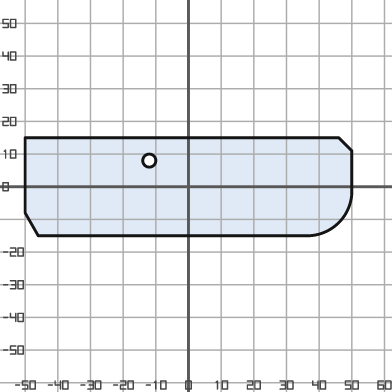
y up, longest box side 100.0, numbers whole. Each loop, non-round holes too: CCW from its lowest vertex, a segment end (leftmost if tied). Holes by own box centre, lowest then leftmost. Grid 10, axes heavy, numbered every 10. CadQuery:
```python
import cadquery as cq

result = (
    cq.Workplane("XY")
    .moveTo(-46.0, -15.0)
    .lineTo(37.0, -15.0)
    .threePointArc((46.0, -11.0), (50.0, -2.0))
    .lineTo(50.0, 11.0)
    .lineTo(46.0, 15.0)
    .lineTo(-50.0, 15.0)
    .lineTo(-50.0, -8.0)
    .close()
    .moveTo(-12.0, 8.0)
    .circle(2.0)
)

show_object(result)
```